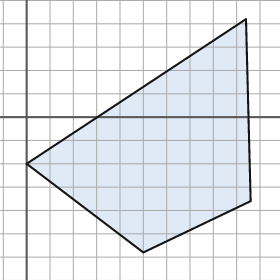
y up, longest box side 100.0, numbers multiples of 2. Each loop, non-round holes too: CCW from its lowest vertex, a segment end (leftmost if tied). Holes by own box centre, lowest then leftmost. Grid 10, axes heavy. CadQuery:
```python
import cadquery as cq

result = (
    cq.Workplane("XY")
    .moveTo(50.0, -58.0)
    .lineTo(96.0, -36.0)
    .lineTo(94.0, 42.0)
    .lineTo(0.0, -20.0)
    .close()
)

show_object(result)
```